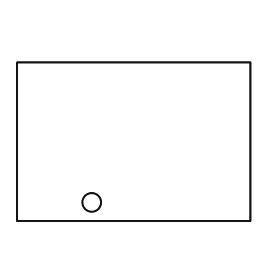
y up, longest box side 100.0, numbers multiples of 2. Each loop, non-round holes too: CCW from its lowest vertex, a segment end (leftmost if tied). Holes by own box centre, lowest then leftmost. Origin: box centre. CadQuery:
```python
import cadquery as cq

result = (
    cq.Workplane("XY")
    .moveTo(-50.0, -34.0)
    .lineTo(50.0, -34.0)
    .lineTo(50.0, 34.0)
    .lineTo(-50.0, 34.0)
    .close()
    .moveTo(-18.0, -26.0)
    .circle(4.0)
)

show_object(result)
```